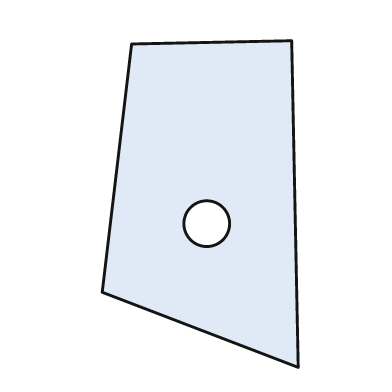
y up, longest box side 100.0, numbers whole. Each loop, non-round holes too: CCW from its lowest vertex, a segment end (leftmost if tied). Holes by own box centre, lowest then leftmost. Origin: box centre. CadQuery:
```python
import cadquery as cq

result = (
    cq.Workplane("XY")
    .moveTo(30.0, -50.0)
    .lineTo(28.0, 50.0)
    .lineTo(-21.0, 49.0)
    .lineTo(-30.0, -27.0)
    .close()
    .moveTo(2.0, -6.0)
    .circle(7.0)
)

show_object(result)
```